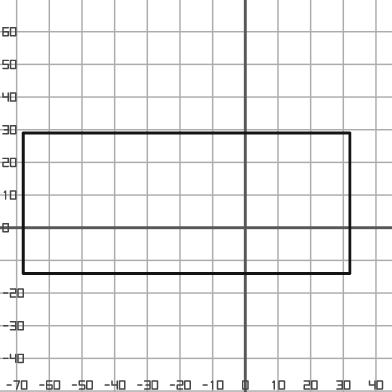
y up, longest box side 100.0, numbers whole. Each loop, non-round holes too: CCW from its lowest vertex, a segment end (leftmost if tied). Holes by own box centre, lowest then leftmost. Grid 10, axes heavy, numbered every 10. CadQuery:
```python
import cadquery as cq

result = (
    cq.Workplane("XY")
    .moveTo(-68.0, -14.0)
    .lineTo(32.0, -14.0)
    .lineTo(32.0, 29.0)
    .lineTo(-68.0, 29.0)
    .close()
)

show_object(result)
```